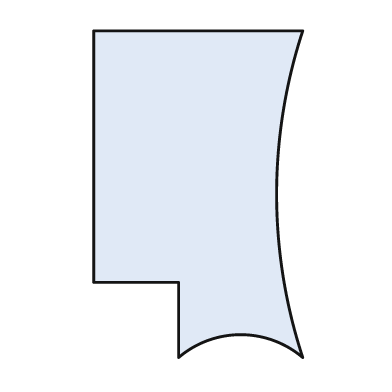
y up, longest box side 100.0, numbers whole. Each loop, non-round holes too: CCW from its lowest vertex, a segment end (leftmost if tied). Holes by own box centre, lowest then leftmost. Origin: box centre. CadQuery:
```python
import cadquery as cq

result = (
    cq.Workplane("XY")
    .moveTo(-6.0, -50.0)
    .threePointArc((13.0, -43.0), (32.0, -50.0))
    .threePointArc((24.0, 0.0), (32.0, 50.0))
    .lineTo(-32.0, 50.0)
    .lineTo(-32.0, -27.0)
    .lineTo(-6.0, -27.0)
    .close()
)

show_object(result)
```